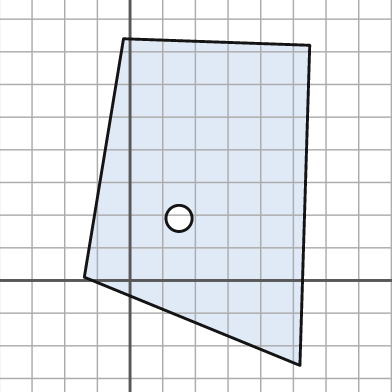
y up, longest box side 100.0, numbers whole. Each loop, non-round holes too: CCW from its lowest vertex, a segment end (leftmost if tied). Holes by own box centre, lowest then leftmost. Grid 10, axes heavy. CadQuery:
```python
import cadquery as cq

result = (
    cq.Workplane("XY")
    .moveTo(52.0, -26.0)
    .lineTo(55.0, 72.0)
    .lineTo(-2.0, 74.0)
    .lineTo(-14.0, 1.0)
    .close()
    .moveTo(15.0, 19.0)
    .circle(4.0)
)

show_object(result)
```